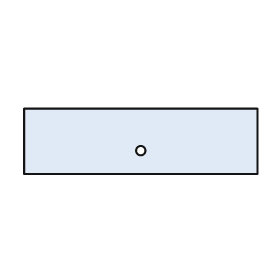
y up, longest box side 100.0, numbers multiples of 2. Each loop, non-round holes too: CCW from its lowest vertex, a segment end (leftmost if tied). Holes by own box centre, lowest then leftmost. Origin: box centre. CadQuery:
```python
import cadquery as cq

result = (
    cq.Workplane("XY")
    .moveTo(-50.0, -14.0)
    .lineTo(50.0, -14.0)
    .lineTo(50.0, 14.0)
    .lineTo(-50.0, 14.0)
    .close()
    .moveTo(0.0, -4.0)
    .circle(2.0)
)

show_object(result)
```